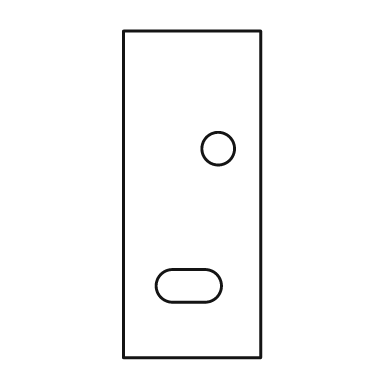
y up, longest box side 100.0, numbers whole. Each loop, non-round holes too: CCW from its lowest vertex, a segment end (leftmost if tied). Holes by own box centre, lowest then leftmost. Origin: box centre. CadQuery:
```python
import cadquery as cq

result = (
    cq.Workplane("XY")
    .moveTo(-21.0, -50.0)
    .lineTo(21.0, -50.0)
    .lineTo(21.0, 50.0)
    .lineTo(-21.0, 50.0)
    .close()
    .moveTo(-6.0, -33.0)
    .lineTo(4.0, -33.0)
    .threePointArc((9.0, -28.0), (4.0, -23.0))
    .lineTo(-6.0, -23.0)
    .threePointArc((-11.0, -28.0), (-6.0, -33.0))
    .close()
    .moveTo(8.0, 14.0)
    .circle(5.0)
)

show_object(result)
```